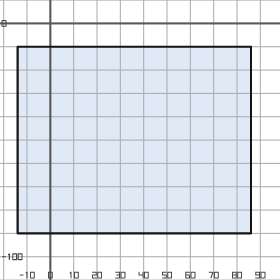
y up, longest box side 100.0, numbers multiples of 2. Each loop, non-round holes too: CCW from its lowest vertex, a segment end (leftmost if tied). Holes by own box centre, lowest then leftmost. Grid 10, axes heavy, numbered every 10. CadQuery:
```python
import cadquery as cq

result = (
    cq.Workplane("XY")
    .moveTo(-14.0, -90.0)
    .lineTo(86.0, -90.0)
    .lineTo(86.0, -10.0)
    .lineTo(-14.0, -10.0)
    .close()
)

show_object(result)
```